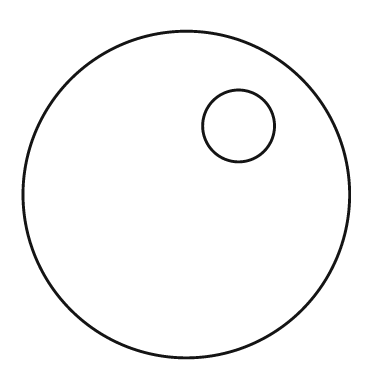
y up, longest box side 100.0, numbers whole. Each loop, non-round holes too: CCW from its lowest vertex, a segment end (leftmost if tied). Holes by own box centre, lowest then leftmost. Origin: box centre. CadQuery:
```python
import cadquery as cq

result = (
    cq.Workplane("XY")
    .moveTo(0.0, 0.0)
    .circle(50.0)
    .moveTo(16.0, 21.0)
    .circle(11.0)
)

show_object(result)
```